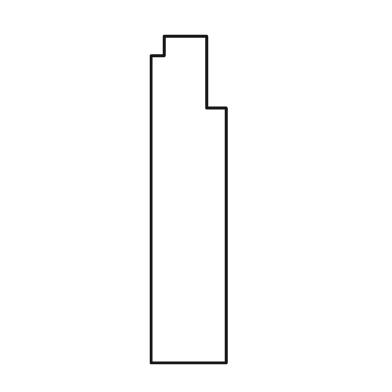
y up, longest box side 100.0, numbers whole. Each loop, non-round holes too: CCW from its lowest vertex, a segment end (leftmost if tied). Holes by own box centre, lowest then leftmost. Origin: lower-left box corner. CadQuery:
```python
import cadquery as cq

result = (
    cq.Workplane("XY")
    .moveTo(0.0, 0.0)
    .lineTo(23.0, 0.0)
    .lineTo(23.0, 78.0)
    .lineTo(17.0, 78.0)
    .lineTo(17.0, 100.0)
    .lineTo(4.0, 100.0)
    .lineTo(4.0, 94.0)
    .lineTo(0.0, 94.0)
    .close()
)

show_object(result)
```